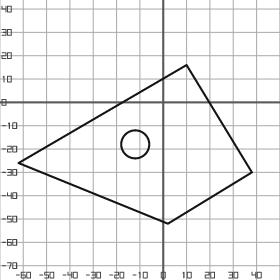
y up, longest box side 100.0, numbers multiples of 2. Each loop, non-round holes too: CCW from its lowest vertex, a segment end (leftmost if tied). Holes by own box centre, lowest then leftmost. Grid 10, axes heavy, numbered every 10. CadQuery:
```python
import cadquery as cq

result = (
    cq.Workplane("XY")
    .moveTo(2.0, -52.0)
    .lineTo(38.0, -30.0)
    .lineTo(10.0, 16.0)
    .lineTo(-62.0, -26.0)
    .close()
    .moveTo(-12.0, -18.0)
    .circle(6.0)
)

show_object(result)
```